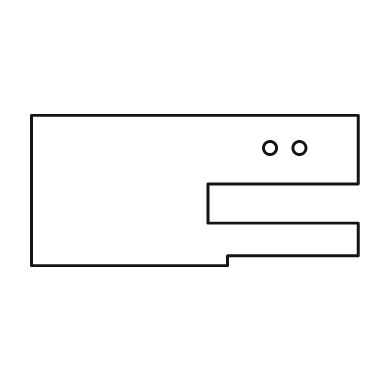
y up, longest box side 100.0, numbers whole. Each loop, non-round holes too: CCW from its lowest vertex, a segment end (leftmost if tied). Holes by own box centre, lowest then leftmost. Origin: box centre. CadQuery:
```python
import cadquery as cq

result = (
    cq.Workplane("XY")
    .moveTo(-50.0, -23.0)
    .lineTo(10.0, -23.0)
    .lineTo(10.0, -20.0)
    .lineTo(50.0, -20.0)
    .lineTo(50.0, -10.0)
    .lineTo(4.0, -10.0)
    .lineTo(4.0, 2.0)
    .lineTo(50.0, 2.0)
    .lineTo(50.0, 23.0)
    .lineTo(-50.0, 23.0)
    .close()
    .moveTo(23.0, 13.0)
    .circle(2.0)
    .moveTo(32.0, 13.0)
    .circle(2.0)
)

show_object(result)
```